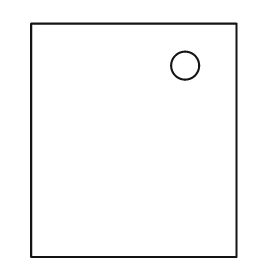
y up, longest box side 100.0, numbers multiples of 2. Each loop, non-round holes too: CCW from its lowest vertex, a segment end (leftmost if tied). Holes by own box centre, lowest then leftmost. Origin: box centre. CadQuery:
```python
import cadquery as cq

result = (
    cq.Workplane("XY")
    .moveTo(-44.0, -50.0)
    .lineTo(44.0, -50.0)
    .lineTo(44.0, 50.0)
    .lineTo(-44.0, 50.0)
    .close()
    .moveTo(22.0, 32.0)
    .circle(6.0)
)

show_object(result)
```